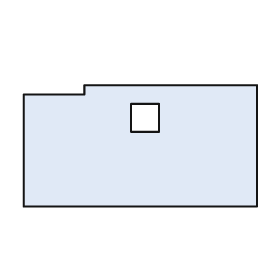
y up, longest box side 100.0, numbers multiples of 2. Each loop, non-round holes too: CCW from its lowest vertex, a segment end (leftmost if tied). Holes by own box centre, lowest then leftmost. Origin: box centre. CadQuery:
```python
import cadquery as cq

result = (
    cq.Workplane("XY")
    .moveTo(-50.0, -26.0)
    .lineTo(50.0, -26.0)
    .lineTo(50.0, 26.0)
    .lineTo(-24.0, 26.0)
    .lineTo(-24.0, 22.0)
    .lineTo(-50.0, 22.0)
    .close()
    .moveTo(-4.0, 6.0)
    .lineTo(8.0, 6.0)
    .lineTo(8.0, 18.0)
    .lineTo(-4.0, 18.0)
    .close()
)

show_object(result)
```